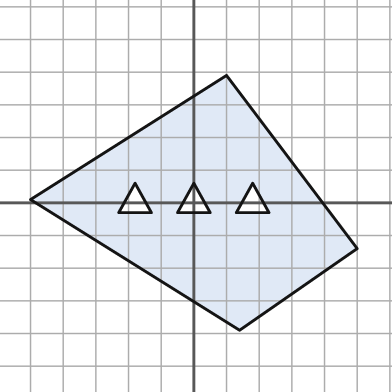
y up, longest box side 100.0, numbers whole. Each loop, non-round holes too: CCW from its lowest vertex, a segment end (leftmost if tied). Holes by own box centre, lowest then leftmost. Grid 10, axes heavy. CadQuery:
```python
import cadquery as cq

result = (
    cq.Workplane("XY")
    .moveTo(14.0, -39.0)
    .lineTo(50.0, -14.0)
    .lineTo(10.0, 39.0)
    .lineTo(-50.0, 1.0)
    .close()
    .moveTo(-23.0, -3.0)
    .lineTo(-13.0, -3.0)
    .lineTo(-18.0, 6.0)
    .close()
    .moveTo(-5.0, -3.0)
    .lineTo(5.0, -3.0)
    .lineTo(0.0, 6.0)
    .close()
    .moveTo(13.0, -3.0)
    .lineTo(23.0, -3.0)
    .lineTo(18.0, 6.0)
    .close()
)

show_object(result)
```